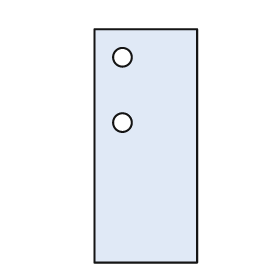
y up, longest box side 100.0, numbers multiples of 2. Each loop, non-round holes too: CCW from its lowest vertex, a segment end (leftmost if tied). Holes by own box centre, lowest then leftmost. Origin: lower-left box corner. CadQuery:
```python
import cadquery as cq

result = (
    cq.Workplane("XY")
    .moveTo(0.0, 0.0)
    .lineTo(44.0, 0.0)
    .lineTo(44.0, 100.0)
    .lineTo(0.0, 100.0)
    .close()
    .moveTo(12.0, 60.0)
    .circle(4.0)
    .moveTo(12.0, 88.0)
    .circle(4.0)
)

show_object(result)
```